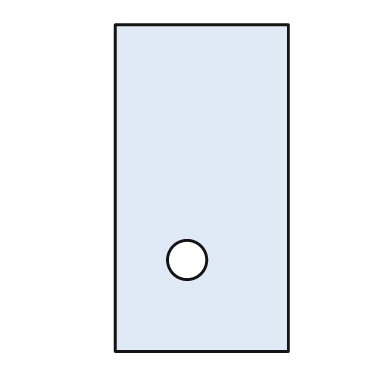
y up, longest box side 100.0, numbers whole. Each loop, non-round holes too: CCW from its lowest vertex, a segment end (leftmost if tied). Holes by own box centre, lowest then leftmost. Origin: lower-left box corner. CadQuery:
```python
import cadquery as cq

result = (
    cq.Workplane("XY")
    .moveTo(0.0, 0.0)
    .lineTo(53.0, 0.0)
    .lineTo(53.0, 100.0)
    .lineTo(0.0, 100.0)
    .close()
    .moveTo(22.0, 28.0)
    .circle(6.0)
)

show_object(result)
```